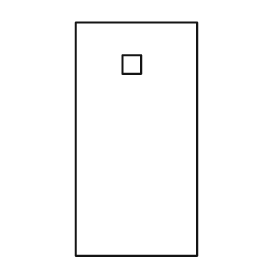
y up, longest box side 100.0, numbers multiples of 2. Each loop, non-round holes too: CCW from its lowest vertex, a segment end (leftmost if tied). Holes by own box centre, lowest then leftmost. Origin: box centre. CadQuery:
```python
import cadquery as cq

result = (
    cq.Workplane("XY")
    .moveTo(-26.0, -50.0)
    .lineTo(26.0, -50.0)
    .lineTo(26.0, 50.0)
    .lineTo(-26.0, 50.0)
    .close()
    .moveTo(-6.0, 28.0)
    .lineTo(2.0, 28.0)
    .lineTo(2.0, 36.0)
    .lineTo(-6.0, 36.0)
    .close()
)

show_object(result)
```